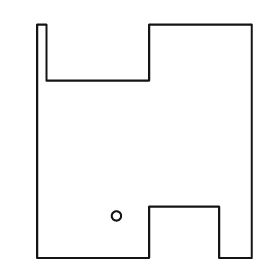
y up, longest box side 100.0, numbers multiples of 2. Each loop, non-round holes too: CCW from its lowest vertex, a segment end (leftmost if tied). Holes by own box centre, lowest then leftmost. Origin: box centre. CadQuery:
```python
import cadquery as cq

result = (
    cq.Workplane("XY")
    .moveTo(-46.0, -50.0)
    .lineTo(2.0, -50.0)
    .lineTo(2.0, -28.0)
    .lineTo(32.0, -28.0)
    .lineTo(32.0, -50.0)
    .lineTo(46.0, -50.0)
    .lineTo(46.0, 50.0)
    .lineTo(2.0, 50.0)
    .lineTo(2.0, 26.0)
    .lineTo(-42.0, 26.0)
    .lineTo(-42.0, 50.0)
    .lineTo(-46.0, 50.0)
    .close()
    .moveTo(-12.0, -32.0)
    .circle(2.0)
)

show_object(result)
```